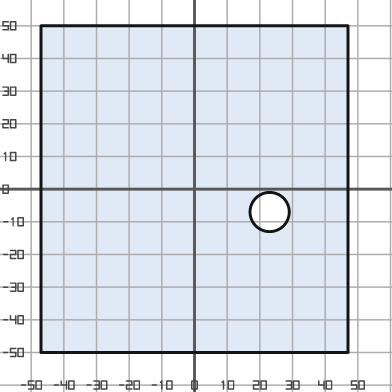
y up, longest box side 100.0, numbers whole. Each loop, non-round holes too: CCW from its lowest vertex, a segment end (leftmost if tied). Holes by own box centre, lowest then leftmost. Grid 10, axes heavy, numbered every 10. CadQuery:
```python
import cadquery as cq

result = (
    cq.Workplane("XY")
    .moveTo(-47.0, -50.0)
    .lineTo(47.0, -50.0)
    .lineTo(47.0, 50.0)
    .lineTo(-47.0, 50.0)
    .close()
    .moveTo(23.0, -7.0)
    .circle(6.0)
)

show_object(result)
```